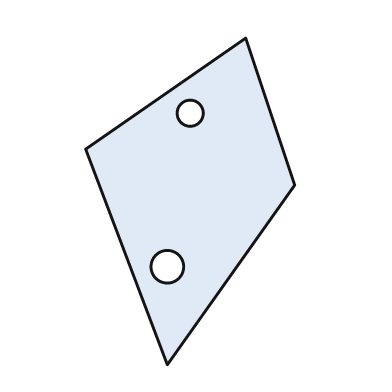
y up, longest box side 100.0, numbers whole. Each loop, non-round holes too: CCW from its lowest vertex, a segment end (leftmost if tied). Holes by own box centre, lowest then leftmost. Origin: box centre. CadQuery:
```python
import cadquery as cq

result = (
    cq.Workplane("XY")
    .moveTo(-7.0, -50.0)
    .lineTo(32.0, 5.0)
    .lineTo(17.0, 50.0)
    .lineTo(-32.0, 16.0)
    .close()
    .moveTo(-7.0, -20.0)
    .circle(5.0)
    .moveTo(0.0, 27.0)
    .circle(4.0)
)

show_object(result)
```